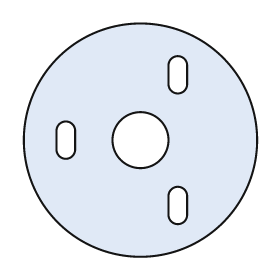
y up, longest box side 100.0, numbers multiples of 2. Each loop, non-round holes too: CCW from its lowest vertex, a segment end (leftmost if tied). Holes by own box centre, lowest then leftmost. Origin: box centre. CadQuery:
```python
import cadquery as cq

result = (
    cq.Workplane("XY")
    .moveTo(0.0, 0.0)
    .circle(50.0)
    .moveTo(12.0, -32.0)
    .threePointArc((16.0, -36.0), (20.0, -32.0))
    .lineTo(20.0, -24.0)
    .threePointArc((16.0, -20.0), (12.0, -24.0))
    .close()
    .moveTo(-36.0, -4.0)
    .threePointArc((-32.0, -8.0), (-28.0, -4.0))
    .lineTo(-28.0, 4.0)
    .threePointArc((-32.0, 8.0), (-36.0, 4.0))
    .close()
    .moveTo(0.0, 0.0)
    .circle(12.0)
    .moveTo(12.0, 24.0)
    .threePointArc((16.0, 20.0), (20.0, 24.0))
    .lineTo(20.0, 32.0)
    .threePointArc((16.0, 36.0), (12.0, 32.0))
    .close()
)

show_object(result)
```